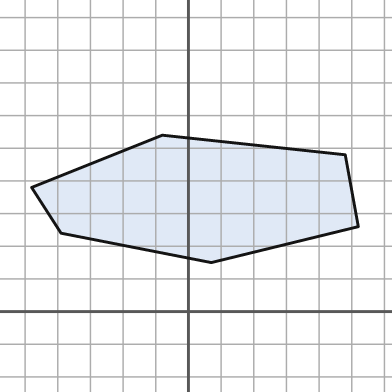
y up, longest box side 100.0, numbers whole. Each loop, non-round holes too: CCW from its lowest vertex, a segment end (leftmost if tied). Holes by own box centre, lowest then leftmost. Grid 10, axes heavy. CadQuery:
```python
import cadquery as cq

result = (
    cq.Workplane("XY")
    .moveTo(7.0, 15.0)
    .lineTo(52.0, 26.0)
    .lineTo(48.0, 48.0)
    .lineTo(-8.0, 54.0)
    .lineTo(-48.0, 38.0)
    .lineTo(-39.0, 24.0)
    .close()
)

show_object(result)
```